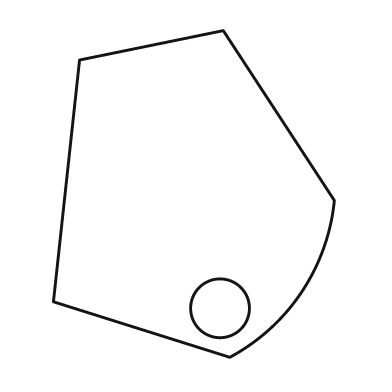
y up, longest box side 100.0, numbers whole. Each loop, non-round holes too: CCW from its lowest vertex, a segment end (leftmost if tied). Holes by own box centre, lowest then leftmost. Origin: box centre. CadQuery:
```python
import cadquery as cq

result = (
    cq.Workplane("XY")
    .moveTo(11.0, -50.0)
    .threePointArc((33.0, -30.0), (43.0, -2.0))
    .lineTo(9.0, 50.0)
    .lineTo(-35.0, 41.0)
    .lineTo(-43.0, -33.0)
    .close()
    .moveTo(8.0, -35.0)
    .circle(9.0)
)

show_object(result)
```